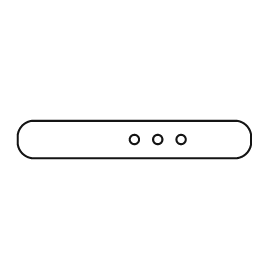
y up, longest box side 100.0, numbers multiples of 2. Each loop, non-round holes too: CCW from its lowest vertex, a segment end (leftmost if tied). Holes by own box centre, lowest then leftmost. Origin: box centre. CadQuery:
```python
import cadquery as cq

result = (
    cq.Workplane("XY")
    .moveTo(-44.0, -8.0)
    .lineTo(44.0, -8.0)
    .threePointArc((48.0, -6.0), (50.0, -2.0))
    .lineTo(50.0, 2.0)
    .threePointArc((48.0, 6.0), (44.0, 8.0))
    .lineTo(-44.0, 8.0)
    .threePointArc((-48.0, 6.0), (-50.0, 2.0))
    .lineTo(-50.0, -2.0)
    .threePointArc((-48.0, -6.0), (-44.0, -8.0))
    .close()
    .moveTo(0.0, 0.0)
    .circle(2.0)
    .moveTo(10.0, 0.0)
    .circle(2.0)
    .moveTo(20.0, 0.0)
    .circle(2.0)
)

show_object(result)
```